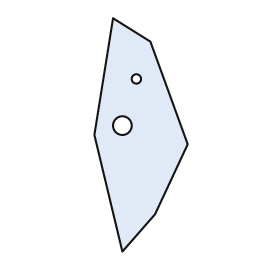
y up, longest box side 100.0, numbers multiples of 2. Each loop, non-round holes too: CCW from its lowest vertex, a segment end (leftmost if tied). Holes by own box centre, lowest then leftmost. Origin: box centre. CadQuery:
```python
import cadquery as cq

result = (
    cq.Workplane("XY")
    .moveTo(-8.0, -50.0)
    .lineTo(6.0, -34.0)
    .lineTo(20.0, -4.0)
    .lineTo(4.0, 40.0)
    .lineTo(-12.0, 50.0)
    .lineTo(-20.0, 0.0)
    .close()
    .moveTo(-8.0, 4.0)
    .circle(4.0)
    .moveTo(-2.0, 24.0)
    .circle(2.0)
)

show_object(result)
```